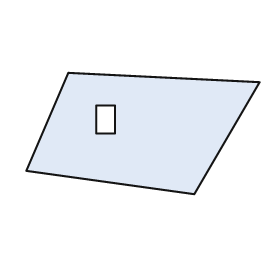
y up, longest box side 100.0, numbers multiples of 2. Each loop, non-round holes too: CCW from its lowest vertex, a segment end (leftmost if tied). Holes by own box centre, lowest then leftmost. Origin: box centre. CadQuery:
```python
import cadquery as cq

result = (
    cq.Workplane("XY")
    .moveTo(22.0, -26.0)
    .lineTo(50.0, 22.0)
    .lineTo(-32.0, 26.0)
    .lineTo(-50.0, -16.0)
    .close()
    .moveTo(-20.0, 0.0)
    .lineTo(-12.0, 0.0)
    .lineTo(-12.0, 12.0)
    .lineTo(-20.0, 12.0)
    .close()
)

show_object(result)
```